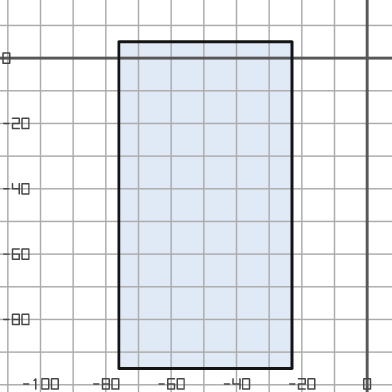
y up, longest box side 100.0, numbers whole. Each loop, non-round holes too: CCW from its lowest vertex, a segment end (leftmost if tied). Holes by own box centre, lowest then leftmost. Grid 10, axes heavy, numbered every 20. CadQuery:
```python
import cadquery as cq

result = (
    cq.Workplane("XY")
    .moveTo(-76.0, -95.0)
    .lineTo(-23.0, -95.0)
    .lineTo(-23.0, 5.0)
    .lineTo(-76.0, 5.0)
    .close()
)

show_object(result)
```